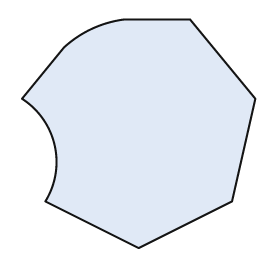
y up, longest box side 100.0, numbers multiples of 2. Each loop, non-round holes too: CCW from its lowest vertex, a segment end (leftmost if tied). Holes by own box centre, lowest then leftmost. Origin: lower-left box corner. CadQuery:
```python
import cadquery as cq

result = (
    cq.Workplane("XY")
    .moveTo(50.0, 0.0)
    .lineTo(90.0, 20.0)
    .lineTo(100.0, 64.0)
    .lineTo(72.0, 98.0)
    .lineTo(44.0, 98.0)
    .threePointArc((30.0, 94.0), (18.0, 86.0))
    .lineTo(0.0, 64.0)
    .threePointArc((14.0, 44.0), (10.0, 20.0))
    .close()
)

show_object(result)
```